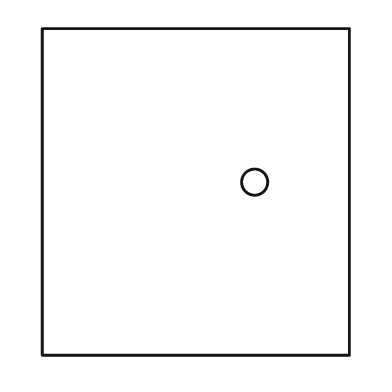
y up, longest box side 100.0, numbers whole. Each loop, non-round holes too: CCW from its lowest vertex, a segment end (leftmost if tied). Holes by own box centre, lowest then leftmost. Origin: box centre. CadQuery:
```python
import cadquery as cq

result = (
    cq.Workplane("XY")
    .moveTo(-47.0, -50.0)
    .lineTo(47.0, -50.0)
    .lineTo(47.0, 50.0)
    .lineTo(-47.0, 50.0)
    .close()
    .moveTo(18.0, 3.0)
    .circle(4.0)
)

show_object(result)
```